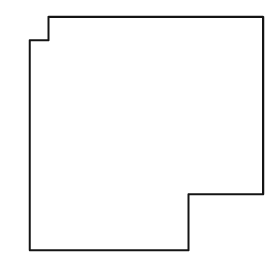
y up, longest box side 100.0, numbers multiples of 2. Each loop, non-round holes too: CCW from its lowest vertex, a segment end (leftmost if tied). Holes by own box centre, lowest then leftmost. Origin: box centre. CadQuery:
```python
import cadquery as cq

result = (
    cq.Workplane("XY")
    .moveTo(-50.0, -50.0)
    .lineTo(18.0, -50.0)
    .lineTo(18.0, -26.0)
    .lineTo(50.0, -26.0)
    .lineTo(50.0, 50.0)
    .lineTo(-42.0, 50.0)
    .lineTo(-42.0, 40.0)
    .lineTo(-50.0, 40.0)
    .close()
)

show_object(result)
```